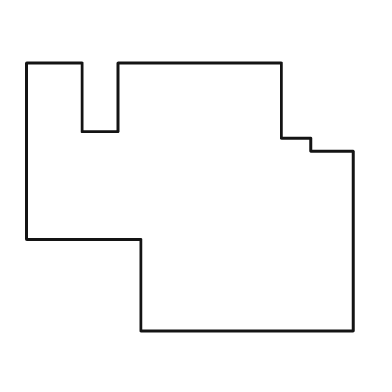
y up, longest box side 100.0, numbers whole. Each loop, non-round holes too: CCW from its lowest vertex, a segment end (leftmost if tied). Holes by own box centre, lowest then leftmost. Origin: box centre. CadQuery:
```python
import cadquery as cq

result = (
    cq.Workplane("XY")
    .moveTo(-15.0, -41.0)
    .lineTo(50.0, -41.0)
    .lineTo(50.0, 14.0)
    .lineTo(37.0, 14.0)
    .lineTo(37.0, 18.0)
    .lineTo(28.0, 18.0)
    .lineTo(28.0, 41.0)
    .lineTo(-22.0, 41.0)
    .lineTo(-22.0, 20.0)
    .lineTo(-33.0, 20.0)
    .lineTo(-33.0, 41.0)
    .lineTo(-50.0, 41.0)
    .lineTo(-50.0, -13.0)
    .lineTo(-15.0, -13.0)
    .close()
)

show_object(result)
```